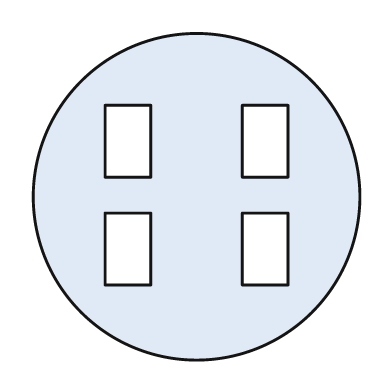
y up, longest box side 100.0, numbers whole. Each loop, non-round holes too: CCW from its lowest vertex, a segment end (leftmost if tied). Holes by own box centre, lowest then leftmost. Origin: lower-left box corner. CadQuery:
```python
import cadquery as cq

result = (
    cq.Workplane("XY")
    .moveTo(50.0, 50.0)
    .circle(50.0)
    .moveTo(22.0, 23.0)
    .lineTo(36.0, 23.0)
    .lineTo(36.0, 45.0)
    .lineTo(22.0, 45.0)
    .close()
    .moveTo(64.0, 23.0)
    .lineTo(78.0, 23.0)
    .lineTo(78.0, 45.0)
    .lineTo(64.0, 45.0)
    .close()
    .moveTo(22.0, 56.0)
    .lineTo(36.0, 56.0)
    .lineTo(36.0, 78.0)
    .lineTo(22.0, 78.0)
    .close()
    .moveTo(64.0, 56.0)
    .lineTo(78.0, 56.0)
    .lineTo(78.0, 78.0)
    .lineTo(64.0, 78.0)
    .close()
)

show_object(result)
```